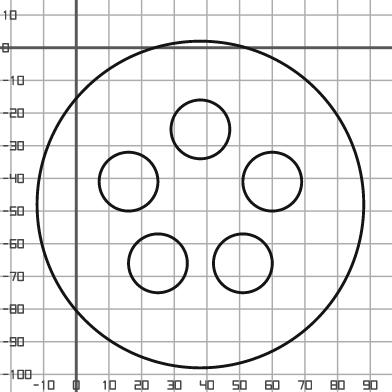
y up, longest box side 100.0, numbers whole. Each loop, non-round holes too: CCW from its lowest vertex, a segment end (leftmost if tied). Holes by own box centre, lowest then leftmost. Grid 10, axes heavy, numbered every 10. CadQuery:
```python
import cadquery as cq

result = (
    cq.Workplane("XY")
    .moveTo(38.0, -48.0)
    .circle(50.0)
    .moveTo(25.0, -66.0)
    .circle(9.0)
    .moveTo(51.0, -66.0)
    .circle(9.0)
    .moveTo(16.0, -41.0)
    .circle(9.0)
    .moveTo(60.0, -41.0)
    .circle(9.0)
    .moveTo(38.0, -25.0)
    .circle(9.0)
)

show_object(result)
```